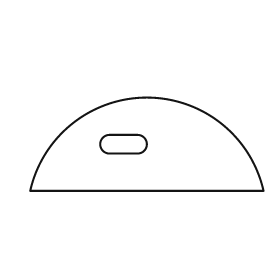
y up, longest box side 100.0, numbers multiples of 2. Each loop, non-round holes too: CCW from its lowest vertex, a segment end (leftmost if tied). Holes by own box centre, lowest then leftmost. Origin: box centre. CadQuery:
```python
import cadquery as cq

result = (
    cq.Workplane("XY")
    .moveTo(-50.0, -20.0)
    .lineTo(50.0, -20.0)
    .threePointArc((0.0, 20.0), (-50.0, -20.0))
    .close()
    .moveTo(-16.0, -4.0)
    .lineTo(-4.0, -4.0)
    .threePointArc((0.0, 0.0), (-4.0, 4.0))
    .lineTo(-16.0, 4.0)
    .threePointArc((-20.0, 0.0), (-16.0, -4.0))
    .close()
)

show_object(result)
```